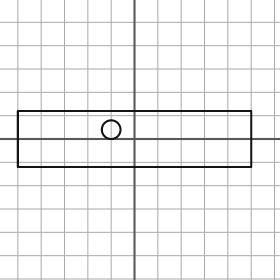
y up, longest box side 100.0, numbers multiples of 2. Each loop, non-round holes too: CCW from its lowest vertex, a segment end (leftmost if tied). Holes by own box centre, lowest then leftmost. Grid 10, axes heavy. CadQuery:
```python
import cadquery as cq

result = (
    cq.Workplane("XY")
    .moveTo(-50.0, -12.0)
    .lineTo(50.0, -12.0)
    .lineTo(50.0, 12.0)
    .lineTo(-50.0, 12.0)
    .close()
    .moveTo(-10.0, 4.0)
    .circle(4.0)
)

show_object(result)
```